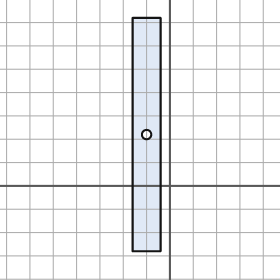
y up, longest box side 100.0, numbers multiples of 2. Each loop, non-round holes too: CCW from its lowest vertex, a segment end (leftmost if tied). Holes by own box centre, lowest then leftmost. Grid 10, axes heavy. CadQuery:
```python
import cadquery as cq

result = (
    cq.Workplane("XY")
    .moveTo(-16.0, -28.0)
    .lineTo(-4.0, -28.0)
    .lineTo(-4.0, 72.0)
    .lineTo(-16.0, 72.0)
    .close()
    .moveTo(-10.0, 22.0)
    .circle(2.0)
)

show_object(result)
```